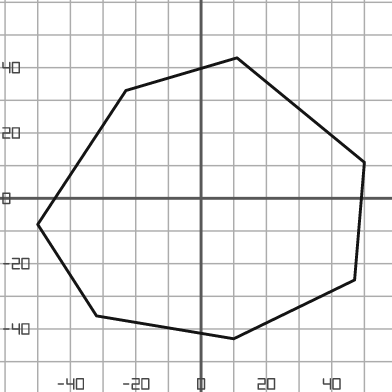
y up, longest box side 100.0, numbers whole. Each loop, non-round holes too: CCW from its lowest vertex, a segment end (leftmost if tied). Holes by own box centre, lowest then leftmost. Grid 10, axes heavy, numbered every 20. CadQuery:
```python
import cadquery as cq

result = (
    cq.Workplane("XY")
    .moveTo(10.0, -43.0)
    .lineTo(47.0, -25.0)
    .lineTo(50.0, 11.0)
    .lineTo(11.0, 43.0)
    .lineTo(-23.0, 33.0)
    .lineTo(-50.0, -8.0)
    .lineTo(-32.0, -36.0)
    .close()
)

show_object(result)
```